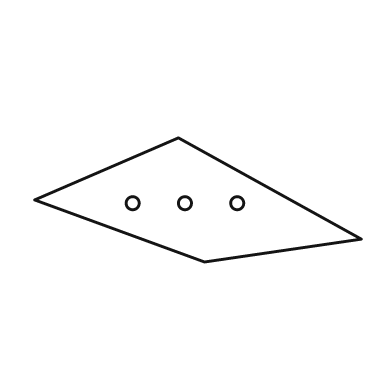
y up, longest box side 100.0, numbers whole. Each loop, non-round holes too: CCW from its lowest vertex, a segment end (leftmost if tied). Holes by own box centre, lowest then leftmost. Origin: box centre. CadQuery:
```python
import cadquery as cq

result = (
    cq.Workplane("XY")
    .moveTo(2.0, -19.0)
    .lineTo(50.0, -12.0)
    .lineTo(-6.0, 19.0)
    .lineTo(-50.0, 0.0)
    .close()
    .moveTo(-20.0, -1.0)
    .circle(2.0)
    .moveTo(-4.0, -1.0)
    .circle(2.0)
    .moveTo(12.0, -1.0)
    .circle(2.0)
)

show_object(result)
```